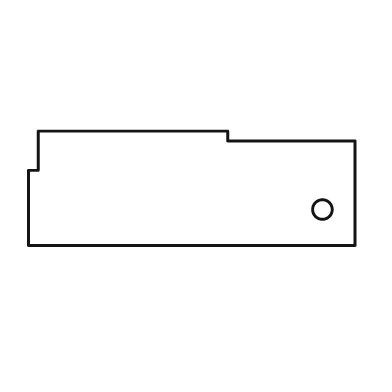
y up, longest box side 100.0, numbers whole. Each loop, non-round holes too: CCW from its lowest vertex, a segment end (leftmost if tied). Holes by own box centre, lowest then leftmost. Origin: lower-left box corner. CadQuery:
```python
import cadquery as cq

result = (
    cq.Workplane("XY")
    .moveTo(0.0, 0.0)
    .lineTo(100.0, 0.0)
    .lineTo(100.0, 32.0)
    .lineTo(61.0, 32.0)
    .lineTo(61.0, 35.0)
    .lineTo(3.0, 35.0)
    .lineTo(3.0, 23.0)
    .lineTo(0.0, 23.0)
    .close()
    .moveTo(90.0, 11.0)
    .circle(3.0)
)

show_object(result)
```